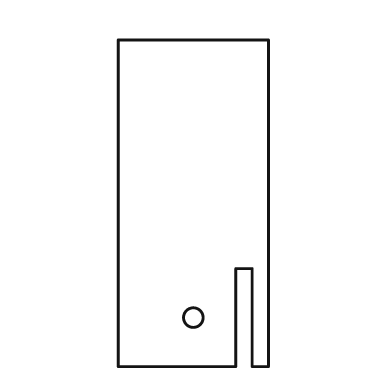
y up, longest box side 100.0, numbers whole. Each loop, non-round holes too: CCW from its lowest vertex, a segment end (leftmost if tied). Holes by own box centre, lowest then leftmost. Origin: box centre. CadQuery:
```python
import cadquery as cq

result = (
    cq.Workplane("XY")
    .moveTo(-23.0, -50.0)
    .lineTo(13.0, -50.0)
    .lineTo(13.0, -20.0)
    .lineTo(18.0, -20.0)
    .lineTo(18.0, -50.0)
    .lineTo(23.0, -50.0)
    .lineTo(23.0, 50.0)
    .lineTo(-23.0, 50.0)
    .close()
    .moveTo(0.0, -35.0)
    .circle(3.0)
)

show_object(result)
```